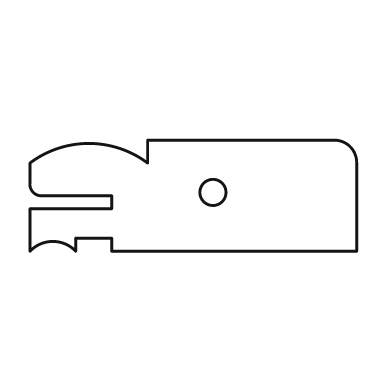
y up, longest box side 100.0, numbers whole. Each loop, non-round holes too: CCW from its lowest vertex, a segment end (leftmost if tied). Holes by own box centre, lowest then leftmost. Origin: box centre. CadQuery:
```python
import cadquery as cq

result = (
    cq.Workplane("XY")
    .moveTo(-50.0, -17.0)
    .threePointArc((-43.0, -14.0), (-36.0, -17.0))
    .lineTo(-36.0, -13.0)
    .lineTo(-25.0, -13.0)
    .lineTo(-25.0, -17.0)
    .lineTo(50.0, -17.0)
    .lineTo(50.0, 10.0)
    .threePointArc((48.0, 15.0), (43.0, 17.0))
    .lineTo(-14.0, 17.0)
    .lineTo(-14.0, 10.0)
    .threePointArc((-32.0, 16.0), (-50.0, 10.0))
    .lineTo(-50.0, 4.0)
    .threePointArc((-49.0, 1.0), (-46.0, 0.0))
    .lineTo(-25.0, 0.0)
    .lineTo(-25.0, -4.0)
    .lineTo(-50.0, -4.0)
    .close()
    .moveTo(6.0, 1.0)
    .circle(4.0)
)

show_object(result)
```